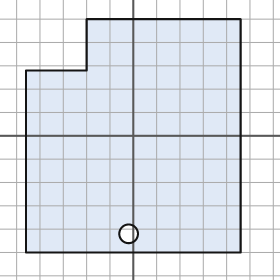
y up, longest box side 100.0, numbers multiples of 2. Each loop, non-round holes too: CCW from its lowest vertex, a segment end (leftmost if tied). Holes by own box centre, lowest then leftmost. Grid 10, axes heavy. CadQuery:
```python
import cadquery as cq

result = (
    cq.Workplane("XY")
    .moveTo(-46.0, -50.0)
    .lineTo(46.0, -50.0)
    .lineTo(46.0, 50.0)
    .lineTo(-20.0, 50.0)
    .lineTo(-20.0, 28.0)
    .lineTo(-46.0, 28.0)
    .close()
    .moveTo(-2.0, -42.0)
    .circle(4.0)
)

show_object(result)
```